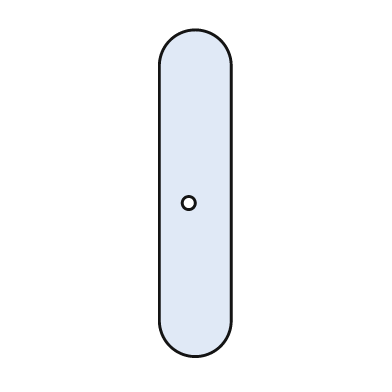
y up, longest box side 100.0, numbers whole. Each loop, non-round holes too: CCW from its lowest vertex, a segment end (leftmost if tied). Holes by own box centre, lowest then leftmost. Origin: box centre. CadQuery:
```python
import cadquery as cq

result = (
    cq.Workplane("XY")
    .moveTo(-11.0, -39.0)
    .threePointArc((0.0, -50.0), (11.0, -39.0))
    .lineTo(11.0, 39.0)
    .threePointArc((0.0, 50.0), (-11.0, 39.0))
    .close()
    .moveTo(-2.0, -3.0)
    .circle(2.0)
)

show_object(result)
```